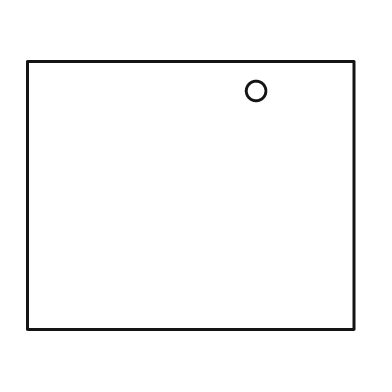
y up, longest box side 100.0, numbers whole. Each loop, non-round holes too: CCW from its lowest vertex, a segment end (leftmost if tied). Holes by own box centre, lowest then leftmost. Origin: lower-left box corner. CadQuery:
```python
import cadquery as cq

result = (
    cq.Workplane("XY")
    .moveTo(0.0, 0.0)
    .lineTo(100.0, 0.0)
    .lineTo(100.0, 82.0)
    .lineTo(0.0, 82.0)
    .close()
    .moveTo(70.0, 73.0)
    .circle(3.0)
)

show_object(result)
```